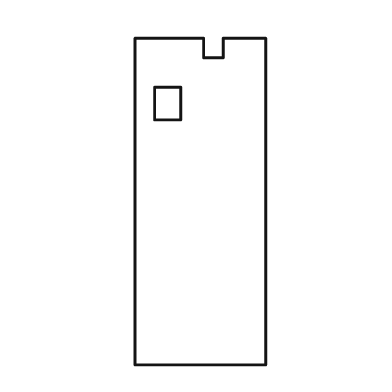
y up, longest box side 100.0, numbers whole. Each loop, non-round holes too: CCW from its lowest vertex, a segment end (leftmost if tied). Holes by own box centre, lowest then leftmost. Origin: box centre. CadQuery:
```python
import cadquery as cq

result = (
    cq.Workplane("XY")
    .moveTo(-20.0, -50.0)
    .lineTo(20.0, -50.0)
    .lineTo(20.0, 50.0)
    .lineTo(7.0, 50.0)
    .lineTo(7.0, 44.0)
    .lineTo(1.0, 44.0)
    .lineTo(1.0, 50.0)
    .lineTo(-20.0, 50.0)
    .close()
    .moveTo(-14.0, 25.0)
    .lineTo(-6.0, 25.0)
    .lineTo(-6.0, 35.0)
    .lineTo(-14.0, 35.0)
    .close()
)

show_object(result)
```